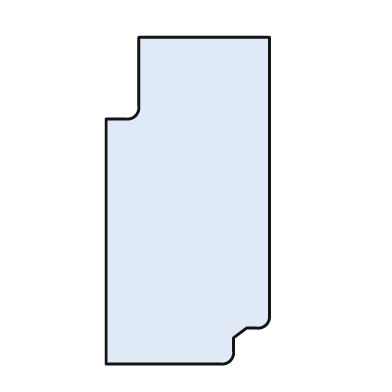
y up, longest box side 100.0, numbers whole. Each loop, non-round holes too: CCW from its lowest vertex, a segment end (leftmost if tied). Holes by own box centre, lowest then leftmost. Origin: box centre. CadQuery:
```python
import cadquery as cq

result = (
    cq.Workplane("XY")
    .moveTo(-25.0, -50.0)
    .lineTo(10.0, -50.0)
    .threePointArc((13.0, -49.0), (14.0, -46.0))
    .lineTo(14.0, -42.0)
    .lineTo(18.0, -39.0)
    .lineTo(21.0, -39.0)
    .threePointArc((24.0, -38.0), (25.0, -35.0))
    .lineTo(25.0, 50.0)
    .lineTo(-15.0, 50.0)
    .lineTo(-15.0, 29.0)
    .threePointArc((-16.0, 26.0), (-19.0, 25.0))
    .lineTo(-25.0, 25.0)
    .close()
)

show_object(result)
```